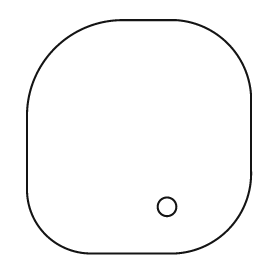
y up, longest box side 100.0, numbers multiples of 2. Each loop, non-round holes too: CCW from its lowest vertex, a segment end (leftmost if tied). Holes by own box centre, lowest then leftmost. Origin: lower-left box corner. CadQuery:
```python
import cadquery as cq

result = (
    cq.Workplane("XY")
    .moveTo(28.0, 0.0)
    .lineTo(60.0, 0.0)
    .threePointArc((86.0, 10.0), (96.0, 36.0))
    .lineTo(96.0, 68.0)
    .threePointArc((86.0, 90.0), (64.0, 100.0))
    .lineTo(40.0, 100.0)
    .threePointArc((12.0, 88.0), (0.0, 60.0))
    .lineTo(0.0, 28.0)
    .threePointArc((8.0, 8.0), (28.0, 0.0))
    .close()
    .moveTo(60.0, 20.0)
    .circle(4.0)
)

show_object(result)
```